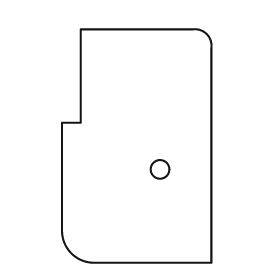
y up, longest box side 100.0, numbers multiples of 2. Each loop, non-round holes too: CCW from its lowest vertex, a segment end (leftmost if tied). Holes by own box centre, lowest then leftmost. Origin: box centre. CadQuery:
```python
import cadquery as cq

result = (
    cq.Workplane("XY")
    .moveTo(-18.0, -50.0)
    .lineTo(32.0, -50.0)
    .lineTo(32.0, 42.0)
    .threePointArc((30.0, 48.0), (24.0, 50.0))
    .lineTo(-24.0, 50.0)
    .lineTo(-24.0, 10.0)
    .lineTo(-32.0, 10.0)
    .lineTo(-32.0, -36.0)
    .threePointArc((-28.0, -46.0), (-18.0, -50.0))
    .close()
    .moveTo(10.0, -10.0)
    .circle(4.0)
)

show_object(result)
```